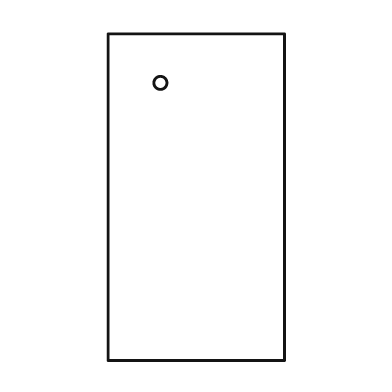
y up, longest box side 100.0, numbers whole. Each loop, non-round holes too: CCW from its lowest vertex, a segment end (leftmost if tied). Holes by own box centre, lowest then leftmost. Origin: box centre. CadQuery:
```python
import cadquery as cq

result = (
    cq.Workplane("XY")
    .moveTo(-27.0, -50.0)
    .lineTo(27.0, -50.0)
    .lineTo(27.0, 50.0)
    .lineTo(-27.0, 50.0)
    .close()
    .moveTo(-11.0, 35.0)
    .circle(2.0)
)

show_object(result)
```